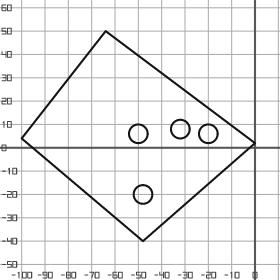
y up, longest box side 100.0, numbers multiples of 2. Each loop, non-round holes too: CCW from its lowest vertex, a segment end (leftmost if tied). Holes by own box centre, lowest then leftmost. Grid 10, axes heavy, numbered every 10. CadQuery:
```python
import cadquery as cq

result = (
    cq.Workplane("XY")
    .moveTo(-48.0, -40.0)
    .lineTo(0.0, 2.0)
    .lineTo(-64.0, 50.0)
    .lineTo(-100.0, 4.0)
    .close()
    .moveTo(-48.0, -20.0)
    .circle(4.0)
    .moveTo(-50.0, 6.0)
    .circle(4.0)
    .moveTo(-20.0, 6.0)
    .circle(4.0)
    .moveTo(-32.0, 8.0)
    .circle(4.0)
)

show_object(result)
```